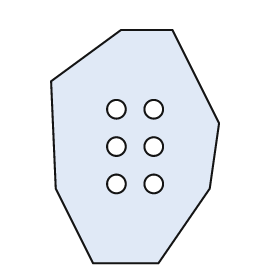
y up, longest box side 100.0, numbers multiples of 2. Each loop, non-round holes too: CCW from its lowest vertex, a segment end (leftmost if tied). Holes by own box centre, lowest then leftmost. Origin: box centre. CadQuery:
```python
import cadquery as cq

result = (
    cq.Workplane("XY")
    .moveTo(-18.0, -50.0)
    .lineTo(10.0, -50.0)
    .lineTo(32.0, -18.0)
    .lineTo(36.0, 10.0)
    .lineTo(16.0, 50.0)
    .lineTo(-6.0, 50.0)
    .lineTo(-36.0, 28.0)
    .lineTo(-34.0, -18.0)
    .close()
    .moveTo(-8.0, -16.0)
    .circle(4.0)
    .moveTo(8.0, -16.0)
    .circle(4.0)
    .moveTo(-8.0, 0.0)
    .circle(4.0)
    .moveTo(8.0, 0.0)
    .circle(4.0)
    .moveTo(-8.0, 16.0)
    .circle(4.0)
    .moveTo(8.0, 16.0)
    .circle(4.0)
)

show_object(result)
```